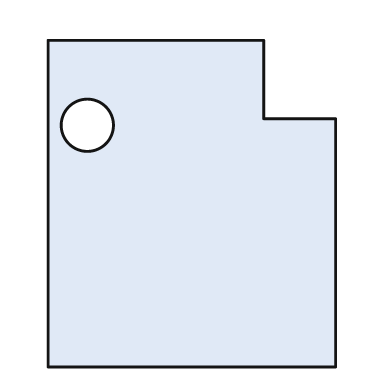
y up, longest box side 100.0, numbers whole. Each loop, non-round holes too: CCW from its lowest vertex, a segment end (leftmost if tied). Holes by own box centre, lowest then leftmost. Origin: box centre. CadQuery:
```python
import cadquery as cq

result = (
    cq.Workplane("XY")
    .moveTo(-44.0, -50.0)
    .lineTo(44.0, -50.0)
    .lineTo(44.0, 26.0)
    .lineTo(22.0, 26.0)
    .lineTo(22.0, 50.0)
    .lineTo(-44.0, 50.0)
    .close()
    .moveTo(-32.0, 24.0)
    .circle(8.0)
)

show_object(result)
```